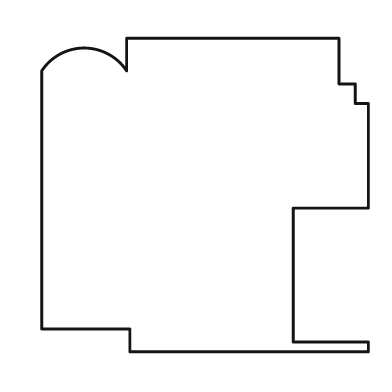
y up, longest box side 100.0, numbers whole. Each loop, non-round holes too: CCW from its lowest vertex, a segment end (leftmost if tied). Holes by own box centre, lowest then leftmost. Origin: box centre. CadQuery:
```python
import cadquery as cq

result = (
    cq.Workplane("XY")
    .moveTo(-23.0, -48.0)
    .lineTo(50.0, -48.0)
    .lineTo(50.0, -45.0)
    .lineTo(27.0, -45.0)
    .lineTo(27.0, -4.0)
    .lineTo(50.0, -4.0)
    .lineTo(50.0, 28.0)
    .lineTo(46.0, 28.0)
    .lineTo(46.0, 34.0)
    .lineTo(41.0, 34.0)
    .lineTo(41.0, 48.0)
    .lineTo(-24.0, 48.0)
    .lineTo(-24.0, 38.0)
    .threePointArc((-37.0, 45.0), (-50.0, 38.0))
    .lineTo(-50.0, -41.0)
    .lineTo(-23.0, -41.0)
    .close()
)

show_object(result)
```